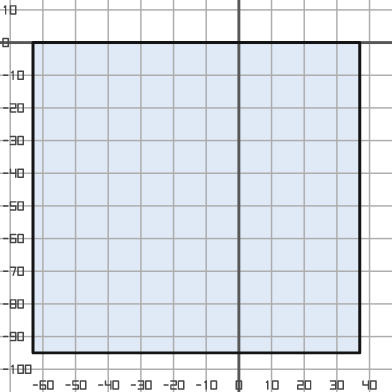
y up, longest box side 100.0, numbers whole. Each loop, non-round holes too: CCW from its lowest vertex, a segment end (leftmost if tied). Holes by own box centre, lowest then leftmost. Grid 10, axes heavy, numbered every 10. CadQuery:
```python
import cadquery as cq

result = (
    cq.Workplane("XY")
    .moveTo(-63.0, -95.0)
    .lineTo(37.0, -95.0)
    .lineTo(37.0, 0.0)
    .lineTo(-63.0, 0.0)
    .close()
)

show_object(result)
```